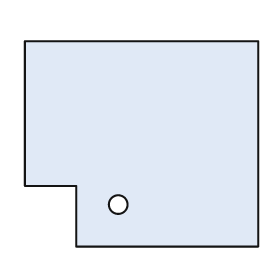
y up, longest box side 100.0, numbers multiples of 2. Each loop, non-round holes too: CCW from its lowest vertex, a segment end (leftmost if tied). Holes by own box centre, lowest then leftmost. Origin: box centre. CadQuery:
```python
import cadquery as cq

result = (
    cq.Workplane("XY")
    .moveTo(-28.0, -44.0)
    .lineTo(50.0, -44.0)
    .lineTo(50.0, 44.0)
    .lineTo(-50.0, 44.0)
    .lineTo(-50.0, -18.0)
    .lineTo(-28.0, -18.0)
    .close()
    .moveTo(-10.0, -26.0)
    .circle(4.0)
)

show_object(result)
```